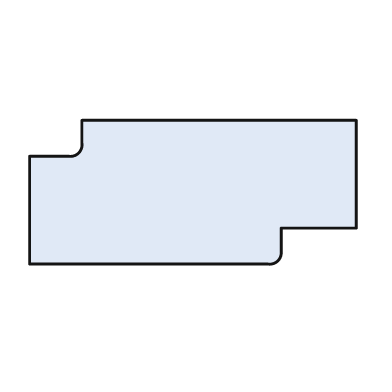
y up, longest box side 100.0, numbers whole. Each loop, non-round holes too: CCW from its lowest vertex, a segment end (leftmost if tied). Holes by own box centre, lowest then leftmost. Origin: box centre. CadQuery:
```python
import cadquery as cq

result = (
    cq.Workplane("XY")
    .moveTo(-50.0, -22.0)
    .lineTo(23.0, -22.0)
    .threePointArc((26.0, -21.0), (27.0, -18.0))
    .lineTo(27.0, -11.0)
    .lineTo(50.0, -11.0)
    .lineTo(50.0, 22.0)
    .lineTo(-34.0, 22.0)
    .lineTo(-34.0, 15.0)
    .threePointArc((-35.0, 12.0), (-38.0, 11.0))
    .lineTo(-50.0, 11.0)
    .close()
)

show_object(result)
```